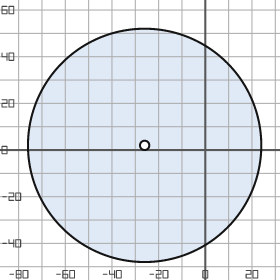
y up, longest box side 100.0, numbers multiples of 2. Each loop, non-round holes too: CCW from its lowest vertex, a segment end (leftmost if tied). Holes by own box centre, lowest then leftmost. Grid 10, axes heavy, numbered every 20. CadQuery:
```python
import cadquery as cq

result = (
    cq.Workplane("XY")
    .moveTo(-26.0, 2.0)
    .circle(50.0)
    .moveTo(-26.0, 2.0)
    .circle(2.0)
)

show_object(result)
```